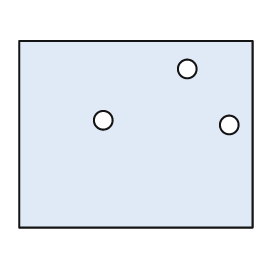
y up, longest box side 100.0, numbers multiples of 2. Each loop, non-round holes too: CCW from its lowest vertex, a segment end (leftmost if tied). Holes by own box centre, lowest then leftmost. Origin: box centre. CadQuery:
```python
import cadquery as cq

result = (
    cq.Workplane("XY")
    .moveTo(-50.0, -40.0)
    .lineTo(50.0, -40.0)
    .lineTo(50.0, 40.0)
    .lineTo(-50.0, 40.0)
    .close()
    .moveTo(40.0, 4.0)
    .circle(4.0)
    .moveTo(-14.0, 6.0)
    .circle(4.0)
    .moveTo(22.0, 28.0)
    .circle(4.0)
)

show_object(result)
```